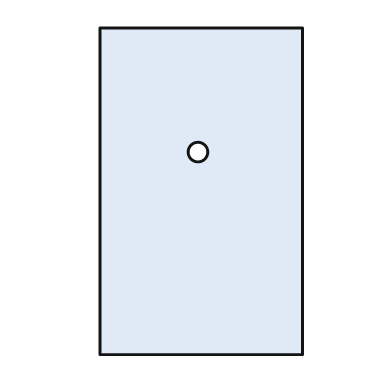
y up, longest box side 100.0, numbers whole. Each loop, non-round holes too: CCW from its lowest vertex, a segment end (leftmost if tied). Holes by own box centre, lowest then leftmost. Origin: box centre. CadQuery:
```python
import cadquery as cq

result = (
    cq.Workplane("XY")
    .moveTo(-31.0, -50.0)
    .lineTo(31.0, -50.0)
    .lineTo(31.0, 50.0)
    .lineTo(-31.0, 50.0)
    .close()
    .moveTo(-1.0, 12.0)
    .circle(3.0)
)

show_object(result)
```